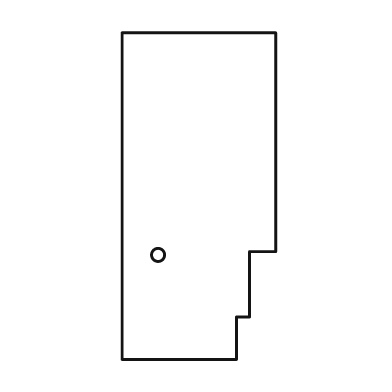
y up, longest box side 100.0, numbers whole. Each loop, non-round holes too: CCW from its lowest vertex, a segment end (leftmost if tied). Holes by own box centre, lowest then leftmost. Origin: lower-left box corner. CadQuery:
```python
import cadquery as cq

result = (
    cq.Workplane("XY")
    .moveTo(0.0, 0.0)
    .lineTo(35.0, 0.0)
    .lineTo(35.0, 13.0)
    .lineTo(39.0, 13.0)
    .lineTo(39.0, 33.0)
    .lineTo(47.0, 33.0)
    .lineTo(47.0, 100.0)
    .lineTo(0.0, 100.0)
    .close()
    .moveTo(11.0, 32.0)
    .circle(2.0)
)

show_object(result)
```